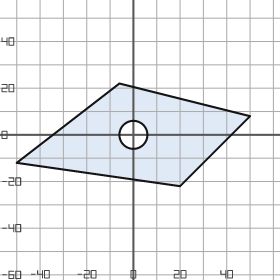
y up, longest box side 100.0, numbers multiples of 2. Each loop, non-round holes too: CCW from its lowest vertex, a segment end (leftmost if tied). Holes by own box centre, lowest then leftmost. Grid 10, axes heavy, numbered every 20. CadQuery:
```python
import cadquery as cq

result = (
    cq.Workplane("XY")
    .moveTo(20.0, -22.0)
    .lineTo(50.0, 8.0)
    .lineTo(-6.0, 22.0)
    .lineTo(-50.0, -12.0)
    .close()
    .moveTo(0.0, 0.0)
    .circle(6.0)
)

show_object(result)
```